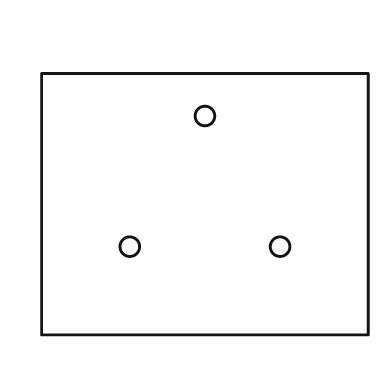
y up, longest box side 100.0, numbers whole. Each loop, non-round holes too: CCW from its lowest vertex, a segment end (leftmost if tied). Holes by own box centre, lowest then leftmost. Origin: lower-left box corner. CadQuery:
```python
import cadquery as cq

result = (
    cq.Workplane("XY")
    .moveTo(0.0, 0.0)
    .lineTo(100.0, 0.0)
    .lineTo(100.0, 80.0)
    .lineTo(0.0, 80.0)
    .close()
    .moveTo(27.0, 27.0)
    .circle(3.0)
    .moveTo(73.0, 27.0)
    .circle(3.0)
    .moveTo(50.0, 67.0)
    .circle(3.0)
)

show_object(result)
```